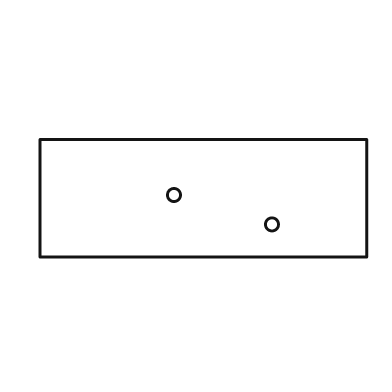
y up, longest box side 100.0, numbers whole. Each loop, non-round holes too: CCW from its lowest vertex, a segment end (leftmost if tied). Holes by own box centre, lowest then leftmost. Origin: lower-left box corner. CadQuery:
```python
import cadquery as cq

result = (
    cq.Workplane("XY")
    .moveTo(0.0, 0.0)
    .lineTo(100.0, 0.0)
    .lineTo(100.0, 36.0)
    .lineTo(0.0, 36.0)
    .close()
    .moveTo(71.0, 10.0)
    .circle(2.0)
    .moveTo(41.0, 19.0)
    .circle(2.0)
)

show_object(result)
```